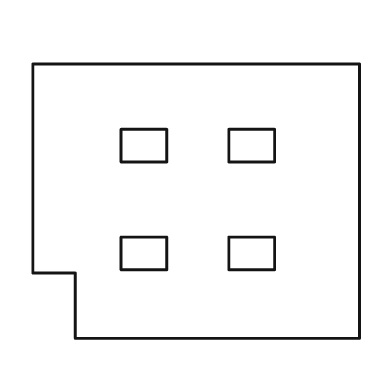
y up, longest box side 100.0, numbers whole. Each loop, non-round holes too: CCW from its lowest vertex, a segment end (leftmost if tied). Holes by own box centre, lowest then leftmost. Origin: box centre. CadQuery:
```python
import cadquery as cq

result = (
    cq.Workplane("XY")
    .moveTo(-37.0, -42.0)
    .lineTo(50.0, -42.0)
    .lineTo(50.0, 42.0)
    .lineTo(-50.0, 42.0)
    .lineTo(-50.0, -22.0)
    .lineTo(-37.0, -22.0)
    .close()
    .moveTo(-23.0, -21.0)
    .lineTo(-9.0, -21.0)
    .lineTo(-9.0, -11.0)
    .lineTo(-23.0, -11.0)
    .close()
    .moveTo(10.0, -21.0)
    .lineTo(24.0, -21.0)
    .lineTo(24.0, -11.0)
    .lineTo(10.0, -11.0)
    .close()
    .moveTo(-23.0, 12.0)
    .lineTo(-9.0, 12.0)
    .lineTo(-9.0, 22.0)
    .lineTo(-23.0, 22.0)
    .close()
    .moveTo(10.0, 12.0)
    .lineTo(24.0, 12.0)
    .lineTo(24.0, 22.0)
    .lineTo(10.0, 22.0)
    .close()
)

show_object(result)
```